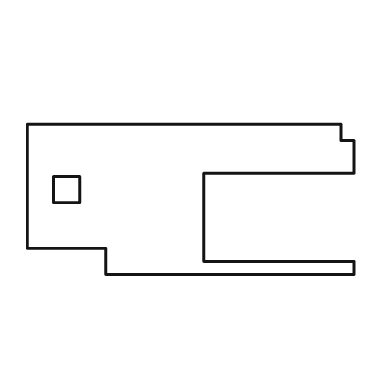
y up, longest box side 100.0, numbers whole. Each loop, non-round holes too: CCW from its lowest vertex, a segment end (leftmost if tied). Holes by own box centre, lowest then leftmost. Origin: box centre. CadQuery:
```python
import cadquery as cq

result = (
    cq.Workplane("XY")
    .moveTo(-26.0, -23.0)
    .lineTo(50.0, -23.0)
    .lineTo(50.0, -19.0)
    .lineTo(4.0, -19.0)
    .lineTo(4.0, 8.0)
    .lineTo(50.0, 8.0)
    .lineTo(50.0, 18.0)
    .lineTo(46.0, 18.0)
    .lineTo(46.0, 23.0)
    .lineTo(-50.0, 23.0)
    .lineTo(-50.0, -15.0)
    .lineTo(-26.0, -15.0)
    .close()
    .moveTo(-42.0, -1.0)
    .lineTo(-34.0, -1.0)
    .lineTo(-34.0, 7.0)
    .lineTo(-42.0, 7.0)
    .close()
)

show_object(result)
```